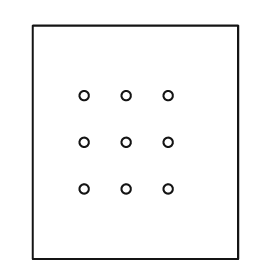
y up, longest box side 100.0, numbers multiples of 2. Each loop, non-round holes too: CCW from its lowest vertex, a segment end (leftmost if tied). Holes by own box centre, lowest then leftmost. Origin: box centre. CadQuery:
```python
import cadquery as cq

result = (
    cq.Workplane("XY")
    .moveTo(-44.0, -50.0)
    .lineTo(44.0, -50.0)
    .lineTo(44.0, 50.0)
    .lineTo(-44.0, 50.0)
    .close()
    .moveTo(-22.0, -20.0)
    .circle(2.0)
    .moveTo(-4.0, -20.0)
    .circle(2.0)
    .moveTo(14.0, -20.0)
    .circle(2.0)
    .moveTo(-22.0, 0.0)
    .circle(2.0)
    .moveTo(-4.0, 0.0)
    .circle(2.0)
    .moveTo(14.0, 0.0)
    .circle(2.0)
    .moveTo(-22.0, 20.0)
    .circle(2.0)
    .moveTo(-4.0, 20.0)
    .circle(2.0)
    .moveTo(14.0, 20.0)
    .circle(2.0)
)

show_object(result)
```